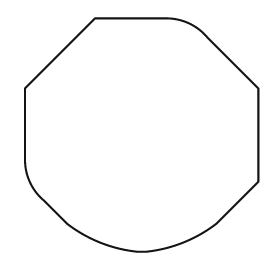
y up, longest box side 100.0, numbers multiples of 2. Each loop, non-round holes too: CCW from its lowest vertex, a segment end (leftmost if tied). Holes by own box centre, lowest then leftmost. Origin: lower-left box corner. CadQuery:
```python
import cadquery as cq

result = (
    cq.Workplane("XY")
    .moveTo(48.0, 0.0)
    .lineTo(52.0, 0.0)
    .threePointArc((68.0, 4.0), (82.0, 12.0))
    .lineTo(100.0, 30.0)
    .lineTo(100.0, 70.0)
    .lineTo(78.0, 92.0)
    .threePointArc((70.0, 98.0), (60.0, 100.0))
    .lineTo(30.0, 100.0)
    .lineTo(0.0, 70.0)
    .lineTo(0.0, 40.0)
    .threePointArc((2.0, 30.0), (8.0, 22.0))
    .lineTo(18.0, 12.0)
    .threePointArc((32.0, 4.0), (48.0, 0.0))
    .close()
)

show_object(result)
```